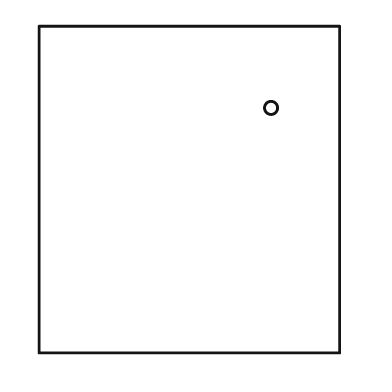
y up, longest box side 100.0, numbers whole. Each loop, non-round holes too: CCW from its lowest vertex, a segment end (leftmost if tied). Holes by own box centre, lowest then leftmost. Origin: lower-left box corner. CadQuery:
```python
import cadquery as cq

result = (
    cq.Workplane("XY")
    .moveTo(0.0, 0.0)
    .lineTo(92.0, 0.0)
    .lineTo(92.0, 100.0)
    .lineTo(0.0, 100.0)
    .close()
    .moveTo(71.0, 75.0)
    .circle(2.0)
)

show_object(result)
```